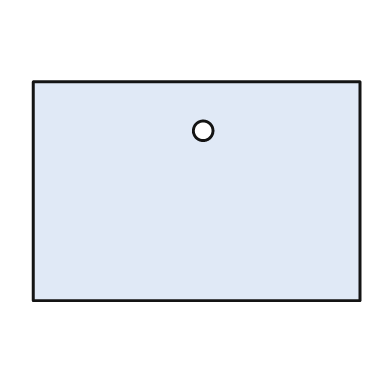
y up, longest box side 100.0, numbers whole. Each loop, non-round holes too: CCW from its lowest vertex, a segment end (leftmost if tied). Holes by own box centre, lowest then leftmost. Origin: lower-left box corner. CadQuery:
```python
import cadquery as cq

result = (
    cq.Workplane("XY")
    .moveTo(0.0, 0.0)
    .lineTo(100.0, 0.0)
    .lineTo(100.0, 67.0)
    .lineTo(0.0, 67.0)
    .close()
    .moveTo(52.0, 52.0)
    .circle(3.0)
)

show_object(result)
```